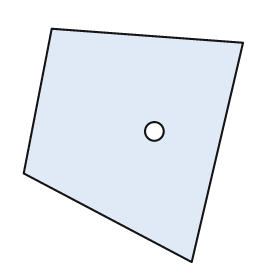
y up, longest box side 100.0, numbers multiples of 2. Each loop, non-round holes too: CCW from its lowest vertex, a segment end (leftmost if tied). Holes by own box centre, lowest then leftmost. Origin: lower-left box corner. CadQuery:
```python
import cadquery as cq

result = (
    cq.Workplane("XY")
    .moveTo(72.0, 0.0)
    .lineTo(94.0, 94.0)
    .lineTo(12.0, 100.0)
    .lineTo(0.0, 38.0)
    .close()
    .moveTo(56.0, 56.0)
    .circle(4.0)
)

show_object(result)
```